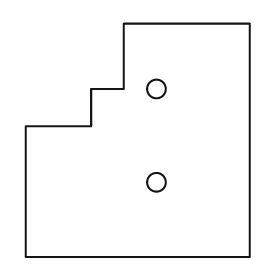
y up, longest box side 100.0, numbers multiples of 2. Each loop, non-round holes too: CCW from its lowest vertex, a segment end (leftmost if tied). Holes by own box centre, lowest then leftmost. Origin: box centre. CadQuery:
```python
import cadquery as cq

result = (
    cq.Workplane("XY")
    .moveTo(-48.0, -50.0)
    .lineTo(48.0, -50.0)
    .lineTo(48.0, 50.0)
    .lineTo(-6.0, 50.0)
    .lineTo(-6.0, 22.0)
    .lineTo(-20.0, 22.0)
    .lineTo(-20.0, 6.0)
    .lineTo(-48.0, 6.0)
    .close()
    .moveTo(8.0, -18.0)
    .circle(4.0)
    .moveTo(8.0, 22.0)
    .circle(4.0)
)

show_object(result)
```